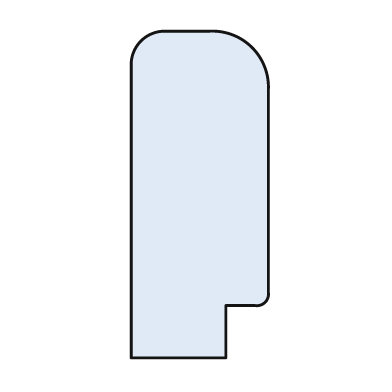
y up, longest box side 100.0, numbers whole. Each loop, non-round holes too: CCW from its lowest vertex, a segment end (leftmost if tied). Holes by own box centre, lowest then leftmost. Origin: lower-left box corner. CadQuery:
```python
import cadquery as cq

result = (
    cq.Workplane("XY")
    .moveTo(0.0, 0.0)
    .lineTo(29.0, 0.0)
    .lineTo(29.0, 16.0)
    .lineTo(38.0, 16.0)
    .threePointArc((41.0, 17.0), (42.0, 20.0))
    .lineTo(42.0, 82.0)
    .threePointArc((37.0, 95.0), (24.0, 100.0))
    .lineTo(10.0, 100.0)
    .threePointArc((3.0, 97.0), (0.0, 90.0))
    .close()
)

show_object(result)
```